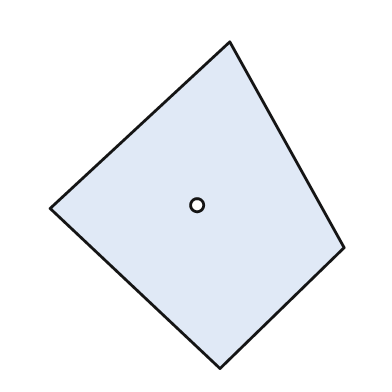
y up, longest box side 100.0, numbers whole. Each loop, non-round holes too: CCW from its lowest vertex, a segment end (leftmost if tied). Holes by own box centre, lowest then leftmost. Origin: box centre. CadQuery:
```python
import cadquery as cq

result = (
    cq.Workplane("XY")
    .moveTo(7.0, -50.0)
    .lineTo(45.0, -13.0)
    .lineTo(10.0, 50.0)
    .lineTo(-45.0, -1.0)
    .close()
    .moveTo(0.0, 0.0)
    .circle(2.0)
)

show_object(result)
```